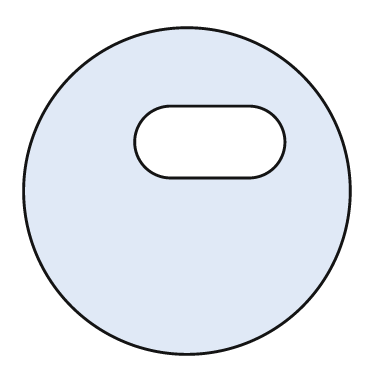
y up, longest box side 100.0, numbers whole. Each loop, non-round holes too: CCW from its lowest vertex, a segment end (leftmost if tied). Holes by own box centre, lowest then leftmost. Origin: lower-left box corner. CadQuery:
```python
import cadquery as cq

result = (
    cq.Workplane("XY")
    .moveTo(50.0, 50.0)
    .circle(50.0)
    .moveTo(45.0, 54.0)
    .lineTo(69.0, 54.0)
    .threePointArc((80.0, 65.0), (69.0, 76.0))
    .lineTo(45.0, 76.0)
    .threePointArc((34.0, 65.0), (45.0, 54.0))
    .close()
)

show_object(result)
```